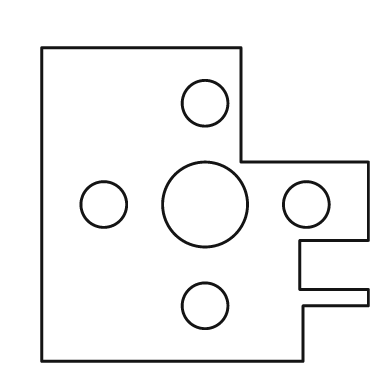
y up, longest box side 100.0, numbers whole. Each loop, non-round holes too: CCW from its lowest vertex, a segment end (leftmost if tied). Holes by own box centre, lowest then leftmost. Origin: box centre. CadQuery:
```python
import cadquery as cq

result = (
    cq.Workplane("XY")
    .moveTo(-50.0, -48.0)
    .lineTo(30.0, -48.0)
    .lineTo(30.0, -31.0)
    .lineTo(50.0, -31.0)
    .lineTo(50.0, -26.0)
    .lineTo(29.0, -26.0)
    .lineTo(29.0, -11.0)
    .lineTo(50.0, -11.0)
    .lineTo(50.0, 13.0)
    .lineTo(11.0, 13.0)
    .lineTo(11.0, 48.0)
    .lineTo(-50.0, 48.0)
    .close()
    .moveTo(0.0, -31.0)
    .circle(7.0)
    .moveTo(-31.0, 0.0)
    .circle(7.0)
    .moveTo(0.0, 0.0)
    .circle(13.0)
    .moveTo(31.0, 0.0)
    .circle(7.0)
    .moveTo(0.0, 31.0)
    .circle(7.0)
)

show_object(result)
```